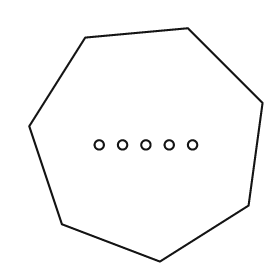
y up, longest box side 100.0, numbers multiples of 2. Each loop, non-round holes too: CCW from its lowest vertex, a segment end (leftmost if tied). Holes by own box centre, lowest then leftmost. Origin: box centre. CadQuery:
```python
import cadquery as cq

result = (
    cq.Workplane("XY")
    .moveTo(6.0, -50.0)
    .lineTo(44.0, -26.0)
    .lineTo(50.0, 18.0)
    .lineTo(18.0, 50.0)
    .lineTo(-26.0, 46.0)
    .lineTo(-50.0, 8.0)
    .lineTo(-36.0, -34.0)
    .close()
    .moveTo(-20.0, 0.0)
    .circle(2.0)
    .moveTo(-10.0, 0.0)
    .circle(2.0)
    .moveTo(0.0, 0.0)
    .circle(2.0)
    .moveTo(10.0, 0.0)
    .circle(2.0)
    .moveTo(20.0, 0.0)
    .circle(2.0)
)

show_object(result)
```